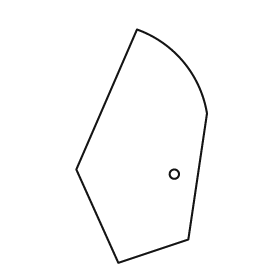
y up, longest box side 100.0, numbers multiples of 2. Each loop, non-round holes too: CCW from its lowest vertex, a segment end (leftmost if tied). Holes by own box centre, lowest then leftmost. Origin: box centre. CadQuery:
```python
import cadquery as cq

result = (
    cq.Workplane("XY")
    .moveTo(-10.0, -50.0)
    .lineTo(20.0, -40.0)
    .lineTo(28.0, 14.0)
    .threePointArc((18.0, 36.0), (-2.0, 50.0))
    .lineTo(-28.0, -10.0)
    .close()
    .moveTo(14.0, -12.0)
    .circle(2.0)
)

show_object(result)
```